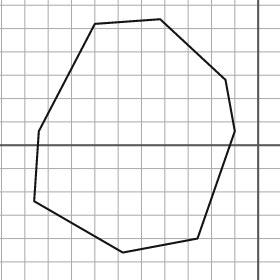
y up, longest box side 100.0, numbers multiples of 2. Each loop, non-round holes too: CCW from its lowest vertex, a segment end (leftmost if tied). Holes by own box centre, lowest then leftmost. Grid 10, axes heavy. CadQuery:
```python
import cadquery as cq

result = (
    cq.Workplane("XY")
    .moveTo(-58.0, -46.0)
    .lineTo(-26.0, -40.0)
    .lineTo(-10.0, 6.0)
    .lineTo(-14.0, 28.0)
    .lineTo(-42.0, 54.0)
    .lineTo(-70.0, 52.0)
    .lineTo(-94.0, 6.0)
    .lineTo(-96.0, -24.0)
    .close()
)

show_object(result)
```